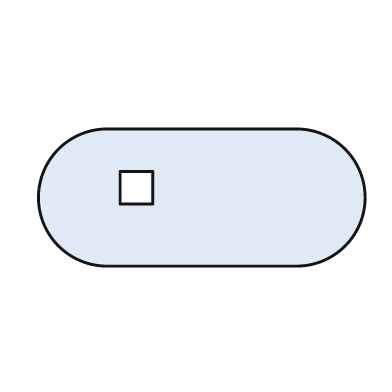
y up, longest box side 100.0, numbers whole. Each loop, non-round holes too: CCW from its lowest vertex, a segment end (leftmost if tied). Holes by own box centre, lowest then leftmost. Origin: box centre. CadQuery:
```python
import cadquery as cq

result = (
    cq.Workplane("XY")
    .moveTo(-29.0, -21.0)
    .lineTo(29.0, -21.0)
    .threePointArc((50.0, 0.0), (29.0, 21.0))
    .lineTo(-29.0, 21.0)
    .threePointArc((-50.0, 0.0), (-29.0, -21.0))
    .close()
    .moveTo(-25.0, -2.0)
    .lineTo(-15.0, -2.0)
    .lineTo(-15.0, 8.0)
    .lineTo(-25.0, 8.0)
    .close()
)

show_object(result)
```